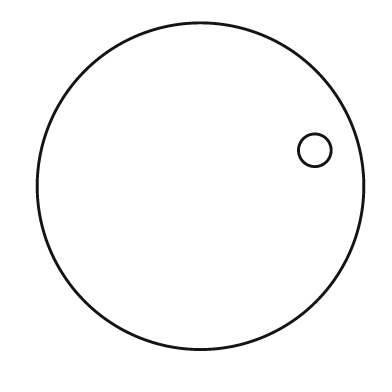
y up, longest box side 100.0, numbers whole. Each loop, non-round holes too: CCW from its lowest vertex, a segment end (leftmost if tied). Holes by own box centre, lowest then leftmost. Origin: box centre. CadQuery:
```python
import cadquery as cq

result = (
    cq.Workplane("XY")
    .moveTo(0.0, 0.0)
    .circle(50.0)
    .moveTo(35.0, 11.0)
    .circle(5.0)
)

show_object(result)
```